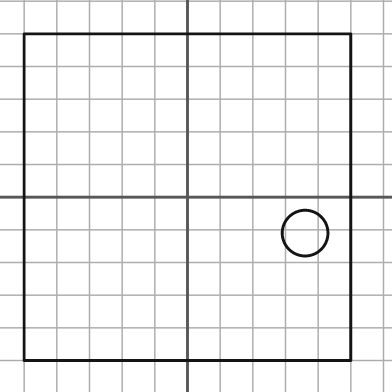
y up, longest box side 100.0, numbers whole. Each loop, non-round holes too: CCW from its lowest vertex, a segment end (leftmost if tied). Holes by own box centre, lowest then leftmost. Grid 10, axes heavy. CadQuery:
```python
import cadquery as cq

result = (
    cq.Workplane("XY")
    .moveTo(-50.0, -50.0)
    .lineTo(50.0, -50.0)
    .lineTo(50.0, 50.0)
    .lineTo(-50.0, 50.0)
    .close()
    .moveTo(36.0, -11.0)
    .circle(7.0)
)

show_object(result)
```